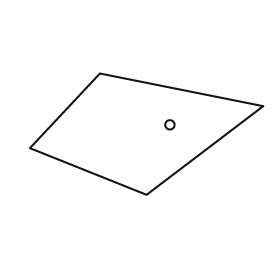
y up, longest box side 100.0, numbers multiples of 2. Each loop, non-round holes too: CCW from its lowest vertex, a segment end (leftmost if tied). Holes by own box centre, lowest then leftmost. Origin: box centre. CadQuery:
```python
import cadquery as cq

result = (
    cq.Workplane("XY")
    .moveTo(0.0, -26.0)
    .lineTo(50.0, 12.0)
    .lineTo(-20.0, 26.0)
    .lineTo(-50.0, -6.0)
    .close()
    .moveTo(10.0, 4.0)
    .circle(2.0)
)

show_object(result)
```